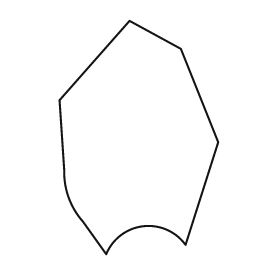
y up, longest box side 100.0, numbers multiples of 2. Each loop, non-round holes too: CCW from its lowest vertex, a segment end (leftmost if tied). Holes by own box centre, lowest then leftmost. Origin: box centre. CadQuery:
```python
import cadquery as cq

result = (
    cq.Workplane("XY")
    .moveTo(-14.0, -50.0)
    .threePointArc((2.0, -38.0), (20.0, -46.0))
    .lineTo(34.0, -2.0)
    .lineTo(18.0, 38.0)
    .lineTo(-4.0, 50.0)
    .lineTo(-34.0, 16.0)
    .lineTo(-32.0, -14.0)
    .threePointArc((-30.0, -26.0), (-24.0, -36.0))
    .close()
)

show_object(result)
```